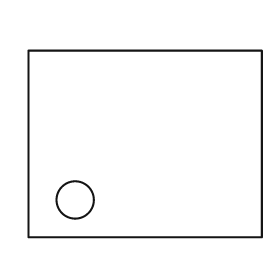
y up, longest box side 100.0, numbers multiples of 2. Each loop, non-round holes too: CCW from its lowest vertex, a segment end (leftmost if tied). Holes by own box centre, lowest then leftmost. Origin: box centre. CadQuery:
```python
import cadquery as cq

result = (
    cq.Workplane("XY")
    .moveTo(-50.0, -40.0)
    .lineTo(50.0, -40.0)
    .lineTo(50.0, 40.0)
    .lineTo(-50.0, 40.0)
    .close()
    .moveTo(-30.0, -24.0)
    .circle(8.0)
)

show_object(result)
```